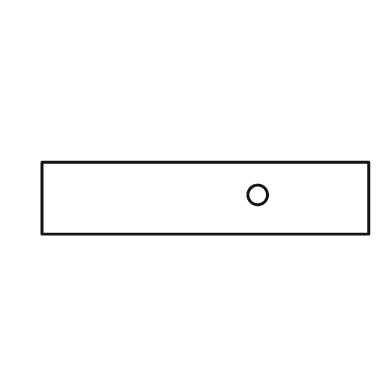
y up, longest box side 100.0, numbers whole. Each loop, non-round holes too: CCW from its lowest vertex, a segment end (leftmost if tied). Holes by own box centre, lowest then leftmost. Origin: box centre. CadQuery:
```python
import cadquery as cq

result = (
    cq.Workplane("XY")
    .moveTo(-50.0, -11.0)
    .lineTo(50.0, -11.0)
    .lineTo(50.0, 11.0)
    .lineTo(-50.0, 11.0)
    .close()
    .moveTo(16.0, 1.0)
    .circle(3.0)
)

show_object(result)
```